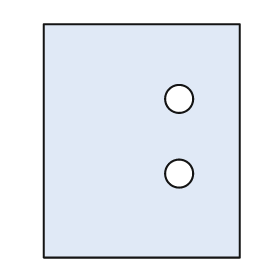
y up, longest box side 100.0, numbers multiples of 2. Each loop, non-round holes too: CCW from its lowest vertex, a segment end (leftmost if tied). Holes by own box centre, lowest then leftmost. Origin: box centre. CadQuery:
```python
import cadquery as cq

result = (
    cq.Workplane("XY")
    .moveTo(-42.0, -50.0)
    .lineTo(42.0, -50.0)
    .lineTo(42.0, 50.0)
    .lineTo(-42.0, 50.0)
    .close()
    .moveTo(16.0, -14.0)
    .circle(6.0)
    .moveTo(16.0, 18.0)
    .circle(6.0)
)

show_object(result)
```